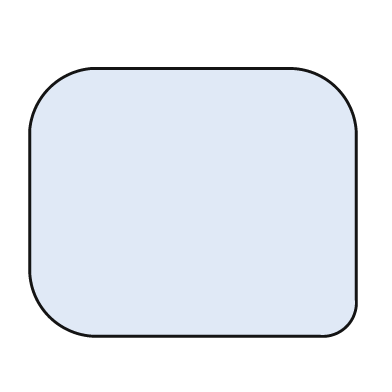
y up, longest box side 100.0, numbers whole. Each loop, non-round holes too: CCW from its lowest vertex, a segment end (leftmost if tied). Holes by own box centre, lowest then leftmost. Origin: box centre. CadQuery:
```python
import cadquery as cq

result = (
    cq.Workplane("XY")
    .moveTo(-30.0, -41.0)
    .lineTo(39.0, -41.0)
    .threePointArc((47.0, -38.0), (50.0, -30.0))
    .lineTo(50.0, 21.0)
    .threePointArc((44.0, 35.0), (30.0, 41.0))
    .lineTo(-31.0, 41.0)
    .threePointArc((-44.0, 35.0), (-50.0, 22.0))
    .lineTo(-50.0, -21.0)
    .threePointArc((-44.0, -35.0), (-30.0, -41.0))
    .close()
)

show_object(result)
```